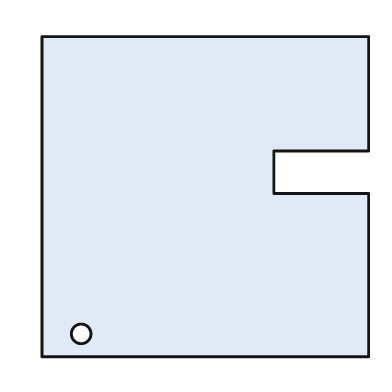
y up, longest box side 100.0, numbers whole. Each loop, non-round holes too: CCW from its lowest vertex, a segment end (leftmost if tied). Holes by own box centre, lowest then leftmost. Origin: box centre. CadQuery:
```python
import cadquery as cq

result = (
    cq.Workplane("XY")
    .moveTo(-50.0, -49.0)
    .lineTo(50.0, -49.0)
    .lineTo(50.0, 1.0)
    .lineTo(21.0, 1.0)
    .lineTo(21.0, 14.0)
    .lineTo(50.0, 14.0)
    .lineTo(50.0, 49.0)
    .lineTo(-50.0, 49.0)
    .close()
    .moveTo(-38.0, -42.0)
    .circle(3.0)
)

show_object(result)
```